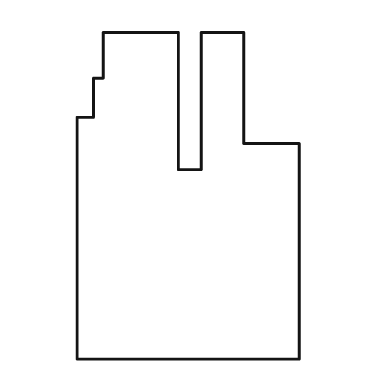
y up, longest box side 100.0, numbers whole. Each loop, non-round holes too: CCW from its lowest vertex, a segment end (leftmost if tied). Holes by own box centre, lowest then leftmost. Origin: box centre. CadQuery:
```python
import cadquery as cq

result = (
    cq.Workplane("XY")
    .moveTo(-34.0, -50.0)
    .lineTo(34.0, -50.0)
    .lineTo(34.0, 16.0)
    .lineTo(17.0, 16.0)
    .lineTo(17.0, 50.0)
    .lineTo(4.0, 50.0)
    .lineTo(4.0, 8.0)
    .lineTo(-3.0, 8.0)
    .lineTo(-3.0, 50.0)
    .lineTo(-26.0, 50.0)
    .lineTo(-26.0, 36.0)
    .lineTo(-29.0, 36.0)
    .lineTo(-29.0, 24.0)
    .lineTo(-34.0, 24.0)
    .close()
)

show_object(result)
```